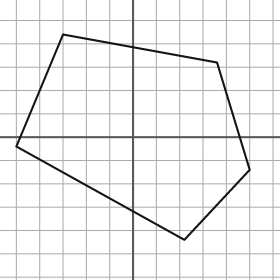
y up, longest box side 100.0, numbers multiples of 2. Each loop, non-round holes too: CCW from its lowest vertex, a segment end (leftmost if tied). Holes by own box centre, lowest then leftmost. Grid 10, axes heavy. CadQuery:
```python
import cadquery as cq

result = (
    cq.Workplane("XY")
    .moveTo(22.0, -44.0)
    .lineTo(50.0, -14.0)
    .lineTo(36.0, 32.0)
    .lineTo(-30.0, 44.0)
    .lineTo(-50.0, -4.0)
    .close()
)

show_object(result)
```